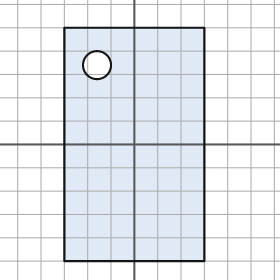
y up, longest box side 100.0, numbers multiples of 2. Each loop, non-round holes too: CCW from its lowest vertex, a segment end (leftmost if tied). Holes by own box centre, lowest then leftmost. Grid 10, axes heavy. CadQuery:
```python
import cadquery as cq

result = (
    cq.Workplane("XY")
    .moveTo(-30.0, -50.0)
    .lineTo(30.0, -50.0)
    .lineTo(30.0, 50.0)
    .lineTo(-30.0, 50.0)
    .close()
    .moveTo(-16.0, 34.0)
    .circle(6.0)
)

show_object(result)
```